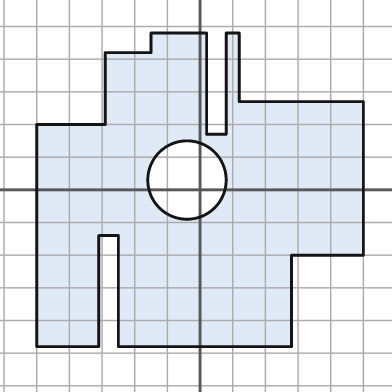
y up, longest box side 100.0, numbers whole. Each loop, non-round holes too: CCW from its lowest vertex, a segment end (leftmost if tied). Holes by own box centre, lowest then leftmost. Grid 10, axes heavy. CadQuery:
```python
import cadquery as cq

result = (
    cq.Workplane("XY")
    .moveTo(-50.0, -48.0)
    .lineTo(-31.0, -48.0)
    .lineTo(-31.0, -14.0)
    .lineTo(-25.0, -14.0)
    .lineTo(-25.0, -48.0)
    .lineTo(28.0, -48.0)
    .lineTo(28.0, -20.0)
    .lineTo(50.0, -20.0)
    .lineTo(50.0, 27.0)
    .lineTo(12.0, 27.0)
    .lineTo(12.0, 48.0)
    .lineTo(8.0, 48.0)
    .lineTo(8.0, 17.0)
    .lineTo(2.0, 17.0)
    .lineTo(2.0, 48.0)
    .lineTo(-15.0, 48.0)
    .lineTo(-15.0, 42.0)
    .lineTo(-29.0, 42.0)
    .lineTo(-29.0, 20.0)
    .lineTo(-50.0, 20.0)
    .close()
    .moveTo(-4.0, 3.0)
    .circle(12.0)
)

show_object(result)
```